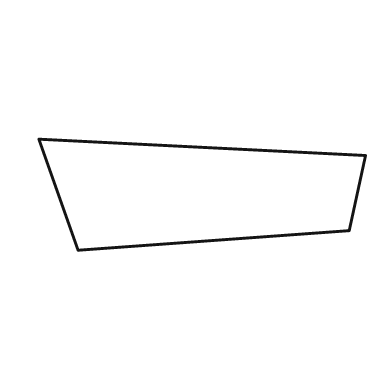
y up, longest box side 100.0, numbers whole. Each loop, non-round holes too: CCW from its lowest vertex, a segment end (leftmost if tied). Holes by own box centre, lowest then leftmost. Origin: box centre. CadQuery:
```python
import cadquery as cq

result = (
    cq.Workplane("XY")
    .moveTo(-38.0, -17.0)
    .lineTo(45.0, -11.0)
    .lineTo(50.0, 12.0)
    .lineTo(-50.0, 17.0)
    .close()
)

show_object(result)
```